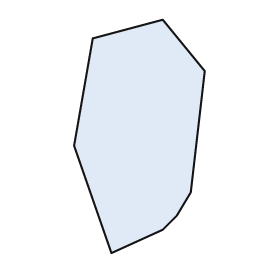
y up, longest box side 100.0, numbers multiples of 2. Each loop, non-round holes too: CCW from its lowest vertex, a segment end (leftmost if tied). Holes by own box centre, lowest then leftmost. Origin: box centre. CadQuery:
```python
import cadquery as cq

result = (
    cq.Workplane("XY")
    .moveTo(-12.0, -50.0)
    .lineTo(10.0, -40.0)
    .lineTo(16.0, -34.0)
    .lineTo(22.0, -24.0)
    .lineTo(28.0, 28.0)
    .lineTo(10.0, 50.0)
    .lineTo(-20.0, 42.0)
    .lineTo(-28.0, -4.0)
    .close()
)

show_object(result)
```